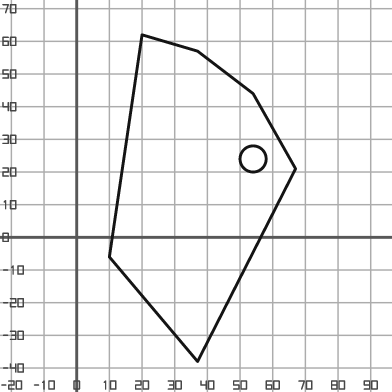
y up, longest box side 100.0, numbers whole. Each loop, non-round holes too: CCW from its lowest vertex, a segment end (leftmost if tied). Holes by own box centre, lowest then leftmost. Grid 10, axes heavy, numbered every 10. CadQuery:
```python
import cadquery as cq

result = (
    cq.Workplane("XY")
    .moveTo(37.0, -38.0)
    .lineTo(67.0, 21.0)
    .lineTo(54.0, 44.0)
    .lineTo(37.0, 57.0)
    .lineTo(20.0, 62.0)
    .lineTo(10.0, -6.0)
    .close()
    .moveTo(54.0, 24.0)
    .circle(4.0)
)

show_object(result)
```